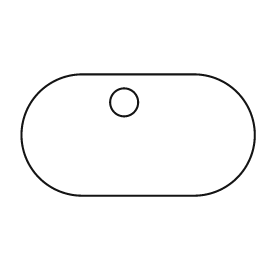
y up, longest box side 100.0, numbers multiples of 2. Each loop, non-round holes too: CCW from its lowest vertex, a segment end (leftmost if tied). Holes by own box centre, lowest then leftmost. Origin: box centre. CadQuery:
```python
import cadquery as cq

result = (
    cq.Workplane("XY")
    .moveTo(-24.0, -26.0)
    .lineTo(24.0, -26.0)
    .threePointArc((50.0, 0.0), (24.0, 26.0))
    .lineTo(-24.0, 26.0)
    .threePointArc((-50.0, 0.0), (-24.0, -26.0))
    .close()
    .moveTo(-6.0, 14.0)
    .circle(6.0)
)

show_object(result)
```